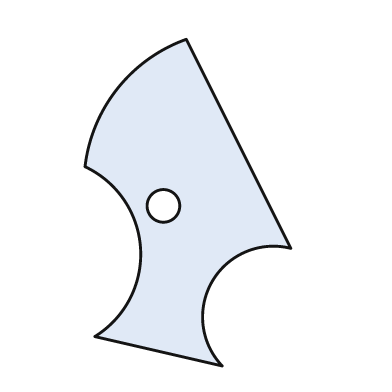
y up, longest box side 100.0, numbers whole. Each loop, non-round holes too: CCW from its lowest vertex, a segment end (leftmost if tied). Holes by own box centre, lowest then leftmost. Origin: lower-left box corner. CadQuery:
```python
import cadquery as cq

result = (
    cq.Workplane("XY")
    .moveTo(42.0, 0.0)
    .threePointArc((39.0, 26.0), (63.0, 36.0))
    .lineTo(31.0, 100.0)
    .threePointArc((10.0, 85.0), (0.0, 61.0))
    .threePointArc((17.0, 36.0), (3.0, 9.0))
    .close()
    .moveTo(24.0, 49.0)
    .circle(5.0)
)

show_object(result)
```